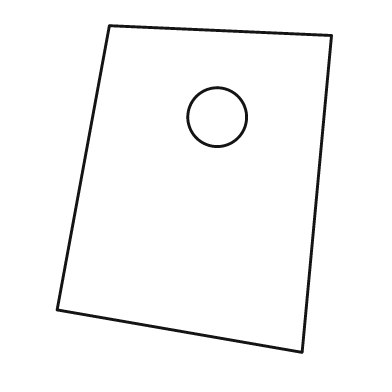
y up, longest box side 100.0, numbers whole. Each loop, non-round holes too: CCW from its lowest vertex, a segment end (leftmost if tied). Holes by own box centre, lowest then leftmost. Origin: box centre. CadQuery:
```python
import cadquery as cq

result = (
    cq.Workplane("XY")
    .moveTo(33.0, -50.0)
    .lineTo(42.0, 47.0)
    .lineTo(-26.0, 50.0)
    .lineTo(-42.0, -37.0)
    .close()
    .moveTo(7.0, 22.0)
    .circle(9.0)
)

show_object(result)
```